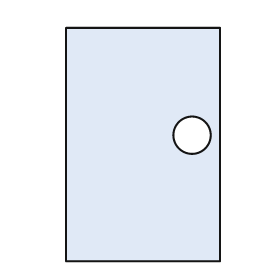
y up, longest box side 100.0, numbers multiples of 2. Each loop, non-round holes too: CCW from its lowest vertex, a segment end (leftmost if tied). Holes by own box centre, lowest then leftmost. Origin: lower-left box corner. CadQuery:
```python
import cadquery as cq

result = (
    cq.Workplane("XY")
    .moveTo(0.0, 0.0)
    .lineTo(66.0, 0.0)
    .lineTo(66.0, 100.0)
    .lineTo(0.0, 100.0)
    .close()
    .moveTo(54.0, 54.0)
    .circle(8.0)
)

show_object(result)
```